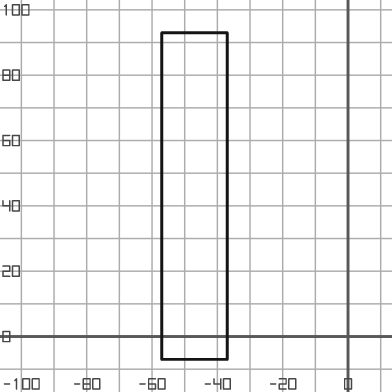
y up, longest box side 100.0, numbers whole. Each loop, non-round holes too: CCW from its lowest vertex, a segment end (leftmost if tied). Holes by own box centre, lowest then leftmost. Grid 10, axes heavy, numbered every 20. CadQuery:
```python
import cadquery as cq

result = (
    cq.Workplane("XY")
    .moveTo(-57.0, -7.0)
    .lineTo(-37.0, -7.0)
    .lineTo(-37.0, 93.0)
    .lineTo(-57.0, 93.0)
    .close()
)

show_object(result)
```